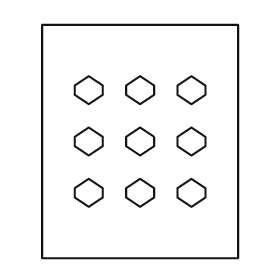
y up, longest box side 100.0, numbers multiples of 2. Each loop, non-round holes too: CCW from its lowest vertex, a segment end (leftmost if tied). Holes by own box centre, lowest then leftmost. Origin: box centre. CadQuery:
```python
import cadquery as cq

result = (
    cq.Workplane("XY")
    .moveTo(-42.0, -50.0)
    .lineTo(42.0, -50.0)
    .lineTo(42.0, 50.0)
    .lineTo(-42.0, 50.0)
    .close()
    .moveTo(-22.0, -28.0)
    .lineTo(-16.0, -24.0)
    .lineTo(-16.0, -20.0)
    .lineTo(-22.0, -16.0)
    .lineTo(-28.0, -20.0)
    .lineTo(-28.0, -24.0)
    .close()
    .moveTo(0.0, -28.0)
    .lineTo(6.0, -24.0)
    .lineTo(6.0, -20.0)
    .lineTo(0.0, -16.0)
    .lineTo(-6.0, -20.0)
    .lineTo(-6.0, -24.0)
    .close()
    .moveTo(22.0, -28.0)
    .lineTo(28.0, -24.0)
    .lineTo(28.0, -20.0)
    .lineTo(22.0, -16.0)
    .lineTo(16.0, -20.0)
    .lineTo(16.0, -24.0)
    .close()
    .moveTo(-22.0, -6.0)
    .lineTo(-16.0, -2.0)
    .lineTo(-16.0, 2.0)
    .lineTo(-22.0, 6.0)
    .lineTo(-28.0, 2.0)
    .lineTo(-28.0, -2.0)
    .close()
    .moveTo(0.0, -6.0)
    .lineTo(6.0, -2.0)
    .lineTo(6.0, 2.0)
    .lineTo(0.0, 6.0)
    .lineTo(-6.0, 2.0)
    .lineTo(-6.0, -2.0)
    .close()
    .moveTo(22.0, -6.0)
    .lineTo(28.0, -2.0)
    .lineTo(28.0, 2.0)
    .lineTo(22.0, 6.0)
    .lineTo(16.0, 2.0)
    .lineTo(16.0, -2.0)
    .close()
    .moveTo(-22.0, 16.0)
    .lineTo(-16.0, 20.0)
    .lineTo(-16.0, 24.0)
    .lineTo(-22.0, 28.0)
    .lineTo(-28.0, 24.0)
    .lineTo(-28.0, 20.0)
    .close()
    .moveTo(0.0, 16.0)
    .lineTo(6.0, 20.0)
    .lineTo(6.0, 24.0)
    .lineTo(0.0, 28.0)
    .lineTo(-6.0, 24.0)
    .lineTo(-6.0, 20.0)
    .close()
    .moveTo(22.0, 16.0)
    .lineTo(28.0, 20.0)
    .lineTo(28.0, 24.0)
    .lineTo(22.0, 28.0)
    .lineTo(16.0, 24.0)
    .lineTo(16.0, 20.0)
    .close()
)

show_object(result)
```